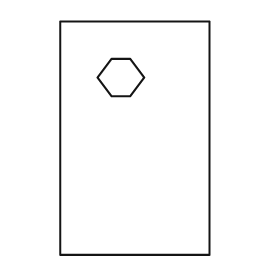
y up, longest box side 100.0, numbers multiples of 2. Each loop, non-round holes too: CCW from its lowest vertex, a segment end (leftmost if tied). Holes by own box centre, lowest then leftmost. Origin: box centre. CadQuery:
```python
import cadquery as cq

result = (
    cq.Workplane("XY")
    .moveTo(-32.0, -50.0)
    .lineTo(32.0, -50.0)
    .lineTo(32.0, 50.0)
    .lineTo(-32.0, 50.0)
    .close()
    .moveTo(-10.0, 18.0)
    .lineTo(-2.0, 18.0)
    .lineTo(4.0, 26.0)
    .lineTo(-2.0, 34.0)
    .lineTo(-10.0, 34.0)
    .lineTo(-16.0, 26.0)
    .close()
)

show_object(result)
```